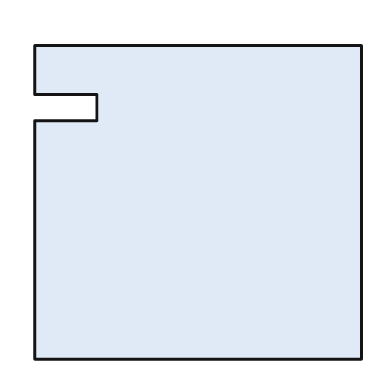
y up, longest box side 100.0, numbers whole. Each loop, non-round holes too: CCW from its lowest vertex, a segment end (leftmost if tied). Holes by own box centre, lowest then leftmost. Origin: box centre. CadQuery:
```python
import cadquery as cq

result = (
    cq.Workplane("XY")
    .moveTo(-50.0, -48.0)
    .lineTo(50.0, -48.0)
    .lineTo(50.0, 48.0)
    .lineTo(-50.0, 48.0)
    .lineTo(-50.0, 33.0)
    .lineTo(-31.0, 33.0)
    .lineTo(-31.0, 25.0)
    .lineTo(-50.0, 25.0)
    .close()
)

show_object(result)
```